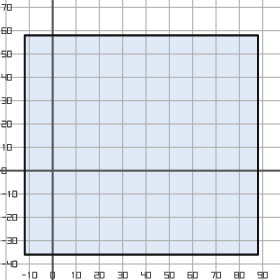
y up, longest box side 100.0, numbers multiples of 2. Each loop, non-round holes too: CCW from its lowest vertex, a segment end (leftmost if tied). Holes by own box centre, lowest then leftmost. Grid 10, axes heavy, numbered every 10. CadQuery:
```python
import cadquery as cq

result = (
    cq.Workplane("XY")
    .moveTo(-12.0, -36.0)
    .lineTo(88.0, -36.0)
    .lineTo(88.0, 58.0)
    .lineTo(-12.0, 58.0)
    .close()
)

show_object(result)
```